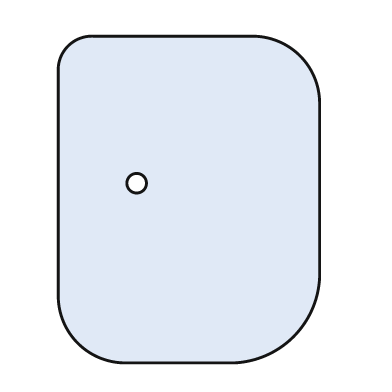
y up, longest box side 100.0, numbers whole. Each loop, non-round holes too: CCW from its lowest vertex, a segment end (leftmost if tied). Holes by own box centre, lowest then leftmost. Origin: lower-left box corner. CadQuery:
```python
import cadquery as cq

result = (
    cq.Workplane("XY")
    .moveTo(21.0, 0.0)
    .lineTo(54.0, 0.0)
    .threePointArc((72.0, 8.0), (80.0, 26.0))
    .lineTo(80.0, 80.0)
    .threePointArc((74.0, 94.0), (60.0, 100.0))
    .lineTo(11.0, 100.0)
    .threePointArc((3.0, 97.0), (0.0, 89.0))
    .lineTo(0.0, 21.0)
    .threePointArc((6.0, 6.0), (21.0, 0.0))
    .close()
    .moveTo(24.0, 55.0)
    .circle(3.0)
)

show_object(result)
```